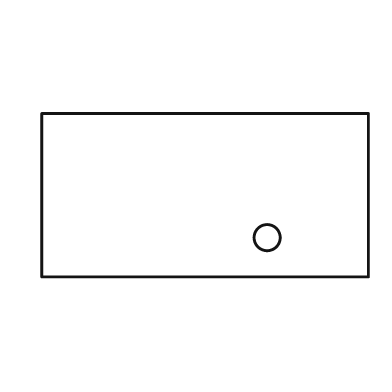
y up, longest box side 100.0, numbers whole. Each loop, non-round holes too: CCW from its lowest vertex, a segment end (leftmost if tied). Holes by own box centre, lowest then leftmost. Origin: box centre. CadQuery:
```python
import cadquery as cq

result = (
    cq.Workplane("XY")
    .moveTo(-50.0, -25.0)
    .lineTo(50.0, -25.0)
    .lineTo(50.0, 25.0)
    .lineTo(-50.0, 25.0)
    .close()
    .moveTo(19.0, -13.0)
    .circle(4.0)
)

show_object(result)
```